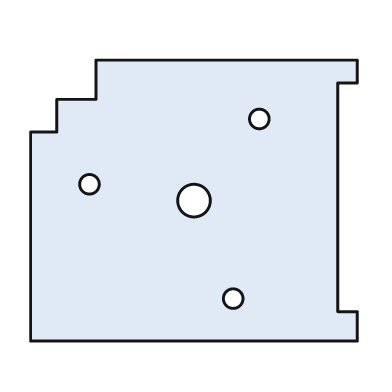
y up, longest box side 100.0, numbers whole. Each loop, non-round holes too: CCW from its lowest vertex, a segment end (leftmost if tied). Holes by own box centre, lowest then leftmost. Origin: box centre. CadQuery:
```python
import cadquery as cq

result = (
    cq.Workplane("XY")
    .moveTo(-50.0, -43.0)
    .lineTo(50.0, -43.0)
    .lineTo(50.0, -34.0)
    .lineTo(44.0, -34.0)
    .lineTo(44.0, 36.0)
    .lineTo(50.0, 36.0)
    .lineTo(50.0, 43.0)
    .lineTo(-30.0, 43.0)
    .lineTo(-30.0, 31.0)
    .lineTo(-42.0, 31.0)
    .lineTo(-42.0, 21.0)
    .lineTo(-50.0, 21.0)
    .close()
    .moveTo(12.0, -30.0)
    .circle(3.0)
    .moveTo(0.0, 0.0)
    .circle(5.0)
    .moveTo(-32.0, 5.0)
    .circle(3.0)
    .moveTo(20.0, 25.0)
    .circle(3.0)
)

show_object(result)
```